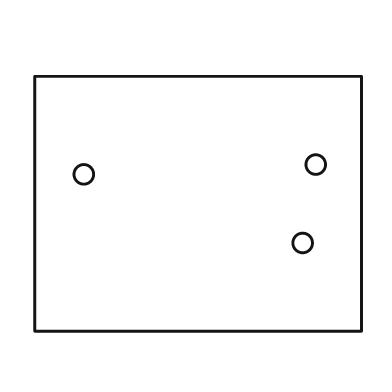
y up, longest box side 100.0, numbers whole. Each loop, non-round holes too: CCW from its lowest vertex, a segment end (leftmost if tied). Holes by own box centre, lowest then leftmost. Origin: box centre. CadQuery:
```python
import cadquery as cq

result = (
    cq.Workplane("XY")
    .moveTo(-50.0, -39.0)
    .lineTo(50.0, -39.0)
    .lineTo(50.0, 39.0)
    .lineTo(-50.0, 39.0)
    .close()
    .moveTo(32.0, -12.0)
    .circle(3.0)
    .moveTo(-35.0, 9.0)
    .circle(3.0)
    .moveTo(36.0, 12.0)
    .circle(3.0)
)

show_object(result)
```